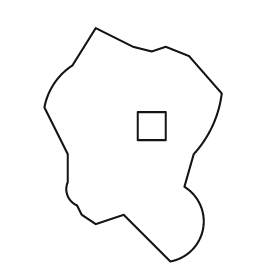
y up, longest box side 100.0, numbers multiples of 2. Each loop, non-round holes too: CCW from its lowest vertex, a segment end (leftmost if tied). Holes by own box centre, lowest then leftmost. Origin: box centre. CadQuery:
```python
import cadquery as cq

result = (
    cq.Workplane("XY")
    .moveTo(16.0, -50.0)
    .threePointArc((30.0, -36.0), (22.0, -18.0))
    .lineTo(26.0, -4.0)
    .threePointArc((34.0, 8.0), (38.0, 22.0))
    .lineTo(24.0, 38.0)
    .lineTo(14.0, 42.0)
    .lineTo(8.0, 40.0)
    .lineTo(0.0, 42.0)
    .lineTo(-16.0, 50.0)
    .lineTo(-26.0, 34.0)
    .threePointArc((-34.0, 26.0), (-38.0, 16.0))
    .lineTo(-28.0, -4.0)
    .lineTo(-28.0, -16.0)
    .threePointArc((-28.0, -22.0), (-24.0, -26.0))
    .lineTo(-22.0, -30.0)
    .lineTo(-16.0, -34.0)
    .lineTo(-4.0, -30.0)
    .close()
    .moveTo(2.0, 2.0)
    .lineTo(14.0, 2.0)
    .lineTo(14.0, 14.0)
    .lineTo(2.0, 14.0)
    .close()
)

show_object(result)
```